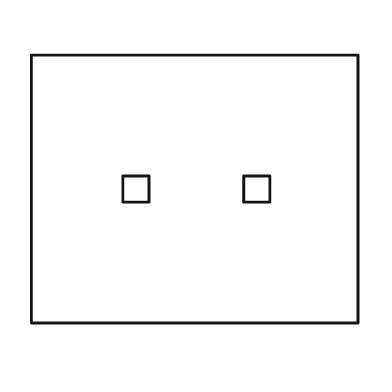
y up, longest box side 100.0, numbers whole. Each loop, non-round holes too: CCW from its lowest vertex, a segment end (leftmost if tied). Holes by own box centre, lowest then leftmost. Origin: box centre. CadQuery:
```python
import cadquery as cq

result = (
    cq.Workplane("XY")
    .moveTo(-50.0, -41.0)
    .lineTo(50.0, -41.0)
    .lineTo(50.0, 41.0)
    .lineTo(-50.0, 41.0)
    .close()
    .moveTo(-22.0, -4.0)
    .lineTo(-14.0, -4.0)
    .lineTo(-14.0, 4.0)
    .lineTo(-22.0, 4.0)
    .close()
    .moveTo(15.0, -4.0)
    .lineTo(23.0, -4.0)
    .lineTo(23.0, 4.0)
    .lineTo(15.0, 4.0)
    .close()
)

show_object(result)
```